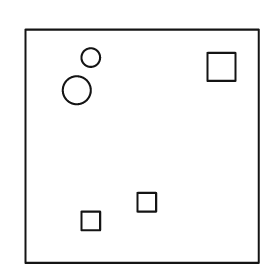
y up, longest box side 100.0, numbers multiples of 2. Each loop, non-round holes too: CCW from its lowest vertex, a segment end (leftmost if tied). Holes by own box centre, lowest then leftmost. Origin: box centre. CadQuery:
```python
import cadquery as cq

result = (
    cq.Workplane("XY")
    .moveTo(-50.0, -50.0)
    .lineTo(50.0, -50.0)
    .lineTo(50.0, 50.0)
    .lineTo(-50.0, 50.0)
    .close()
    .moveTo(-26.0, -36.0)
    .lineTo(-18.0, -36.0)
    .lineTo(-18.0, -28.0)
    .lineTo(-26.0, -28.0)
    .close()
    .moveTo(-2.0, -28.0)
    .lineTo(6.0, -28.0)
    .lineTo(6.0, -20.0)
    .lineTo(-2.0, -20.0)
    .close()
    .moveTo(-28.0, 24.0)
    .circle(6.0)
    .moveTo(28.0, 28.0)
    .lineTo(40.0, 28.0)
    .lineTo(40.0, 40.0)
    .lineTo(28.0, 40.0)
    .close()
    .moveTo(-22.0, 38.0)
    .circle(4.0)
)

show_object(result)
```